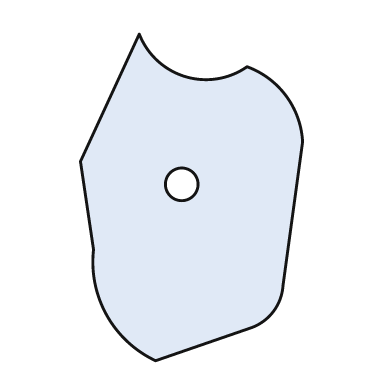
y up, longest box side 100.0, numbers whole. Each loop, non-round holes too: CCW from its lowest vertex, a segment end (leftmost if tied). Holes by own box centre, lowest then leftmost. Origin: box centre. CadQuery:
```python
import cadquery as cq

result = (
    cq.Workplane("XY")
    .moveTo(-11.0, -50.0)
    .lineTo(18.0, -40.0)
    .threePointArc((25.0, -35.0), (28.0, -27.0))
    .lineTo(34.0, 17.0)
    .threePointArc((29.0, 31.0), (17.0, 40.0))
    .threePointArc((-2.0, 37.0), (-16.0, 50.0))
    .lineTo(-34.0, 11.0)
    .lineTo(-30.0, -16.0)
    .threePointArc((-26.0, -36.0), (-11.0, -50.0))
    .close()
    .moveTo(-3.0, 4.0)
    .circle(5.0)
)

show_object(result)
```